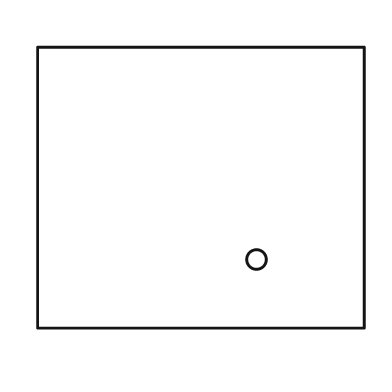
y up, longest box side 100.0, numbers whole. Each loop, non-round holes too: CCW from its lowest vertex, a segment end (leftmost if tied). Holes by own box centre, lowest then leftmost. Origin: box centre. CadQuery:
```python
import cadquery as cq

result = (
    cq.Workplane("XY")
    .moveTo(-50.0, -43.0)
    .lineTo(50.0, -43.0)
    .lineTo(50.0, 43.0)
    .lineTo(-50.0, 43.0)
    .close()
    .moveTo(17.0, -22.0)
    .circle(3.0)
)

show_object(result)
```